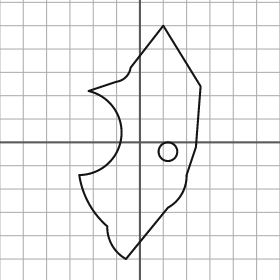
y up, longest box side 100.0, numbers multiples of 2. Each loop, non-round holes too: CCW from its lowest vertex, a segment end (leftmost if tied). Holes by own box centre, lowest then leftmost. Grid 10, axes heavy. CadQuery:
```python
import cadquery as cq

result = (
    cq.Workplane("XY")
    .moveTo(-6.0, -50.0)
    .lineTo(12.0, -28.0)
    .threePointArc((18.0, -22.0), (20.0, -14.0))
    .lineTo(24.0, -2.0)
    .lineTo(26.0, 24.0)
    .lineTo(10.0, 50.0)
    .lineTo(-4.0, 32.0)
    .threePointArc((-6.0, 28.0), (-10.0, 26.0))
    .lineTo(-22.0, 22.0)
    .threePointArc((-8.0, 2.0), (-26.0, -14.0))
    .threePointArc((-22.0, -26.0), (-14.0, -36.0))
    .threePointArc((-12.0, -44.0), (-6.0, -50.0))
    .close()
    .moveTo(12.0, -4.0)
    .circle(4.0)
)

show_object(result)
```